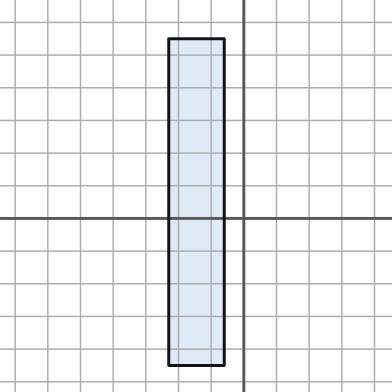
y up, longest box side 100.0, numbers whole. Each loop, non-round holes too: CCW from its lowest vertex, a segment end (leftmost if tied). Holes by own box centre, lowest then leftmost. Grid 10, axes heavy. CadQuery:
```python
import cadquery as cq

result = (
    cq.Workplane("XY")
    .moveTo(-23.0, -45.0)
    .lineTo(-6.0, -45.0)
    .lineTo(-6.0, 55.0)
    .lineTo(-23.0, 55.0)
    .close()
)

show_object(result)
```